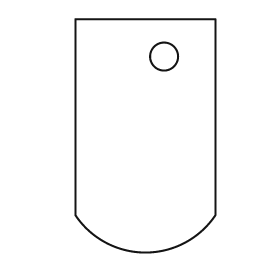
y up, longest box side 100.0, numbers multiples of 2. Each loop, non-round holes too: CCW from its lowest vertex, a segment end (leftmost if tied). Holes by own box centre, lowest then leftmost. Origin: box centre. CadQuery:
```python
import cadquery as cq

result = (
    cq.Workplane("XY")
    .moveTo(-30.0, -34.0)
    .threePointArc((0.0, -50.0), (30.0, -34.0))
    .lineTo(30.0, 50.0)
    .lineTo(-30.0, 50.0)
    .close()
    .moveTo(8.0, 34.0)
    .circle(6.0)
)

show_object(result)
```